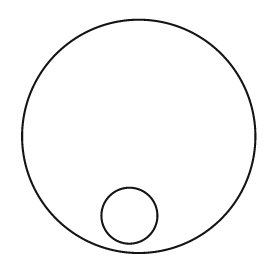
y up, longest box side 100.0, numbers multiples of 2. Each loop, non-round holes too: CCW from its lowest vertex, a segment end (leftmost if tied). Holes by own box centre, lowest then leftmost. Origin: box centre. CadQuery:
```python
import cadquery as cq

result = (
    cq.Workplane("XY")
    .moveTo(0.0, 0.0)
    .circle(50.0)
    .moveTo(-4.0, -34.0)
    .circle(12.0)
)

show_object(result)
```